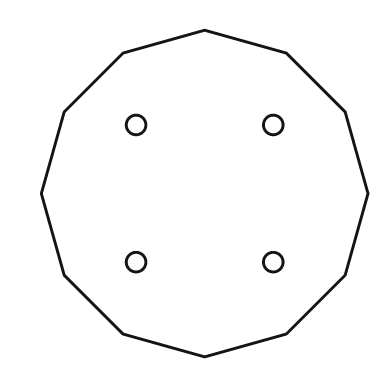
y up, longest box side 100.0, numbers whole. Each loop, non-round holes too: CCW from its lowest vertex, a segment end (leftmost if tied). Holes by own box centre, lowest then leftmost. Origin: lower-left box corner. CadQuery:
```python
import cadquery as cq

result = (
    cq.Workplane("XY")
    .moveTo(50.0, 0.0)
    .lineTo(75.0, 7.0)
    .lineTo(93.0, 25.0)
    .lineTo(100.0, 50.0)
    .lineTo(93.0, 75.0)
    .lineTo(75.0, 93.0)
    .lineTo(50.0, 100.0)
    .lineTo(25.0, 93.0)
    .lineTo(7.0, 75.0)
    .lineTo(0.0, 50.0)
    .lineTo(7.0, 25.0)
    .lineTo(25.0, 7.0)
    .close()
    .moveTo(29.0, 29.0)
    .circle(3.0)
    .moveTo(71.0, 29.0)
    .circle(3.0)
    .moveTo(29.0, 71.0)
    .circle(3.0)
    .moveTo(71.0, 71.0)
    .circle(3.0)
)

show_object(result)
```